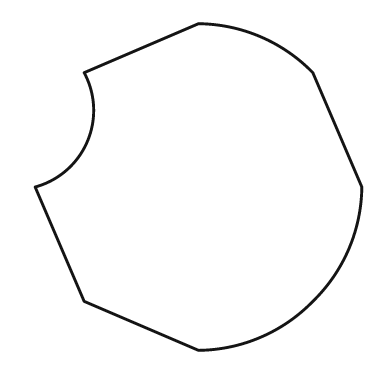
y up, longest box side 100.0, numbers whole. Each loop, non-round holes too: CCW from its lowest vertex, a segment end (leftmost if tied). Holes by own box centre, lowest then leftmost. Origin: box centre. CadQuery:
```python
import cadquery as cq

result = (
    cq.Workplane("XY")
    .moveTo(0.0, -50.0)
    .threePointArc((19.0, -46.0), (35.0, -35.0))
    .threePointArc((46.0, -19.0), (50.0, 0.0))
    .lineTo(35.0, 35.0)
    .threePointArc((19.0, 46.0), (0.0, 50.0))
    .lineTo(-35.0, 35.0)
    .threePointArc((-34.0, 14.0), (-50.0, 0.0))
    .lineTo(-35.0, -35.0)
    .close()
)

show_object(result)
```